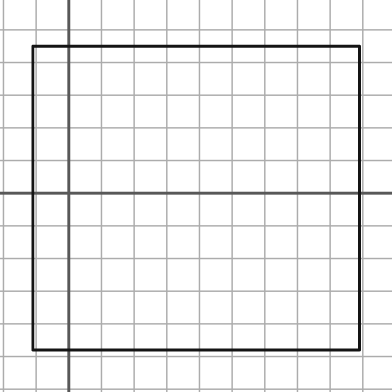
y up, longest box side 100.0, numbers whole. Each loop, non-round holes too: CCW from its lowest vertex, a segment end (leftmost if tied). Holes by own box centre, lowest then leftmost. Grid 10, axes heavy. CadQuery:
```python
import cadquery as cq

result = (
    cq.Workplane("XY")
    .moveTo(-11.0, -48.0)
    .lineTo(89.0, -48.0)
    .lineTo(89.0, 45.0)
    .lineTo(-11.0, 45.0)
    .close()
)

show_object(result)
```